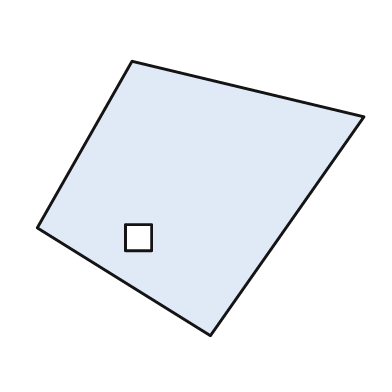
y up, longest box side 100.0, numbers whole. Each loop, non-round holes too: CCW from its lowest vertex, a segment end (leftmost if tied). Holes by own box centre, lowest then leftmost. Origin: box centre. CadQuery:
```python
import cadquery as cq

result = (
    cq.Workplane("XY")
    .moveTo(3.0, -42.0)
    .lineTo(50.0, 25.0)
    .lineTo(-21.0, 42.0)
    .lineTo(-50.0, -9.0)
    .close()
    .moveTo(-23.0, -16.0)
    .lineTo(-15.0, -16.0)
    .lineTo(-15.0, -8.0)
    .lineTo(-23.0, -8.0)
    .close()
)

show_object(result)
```